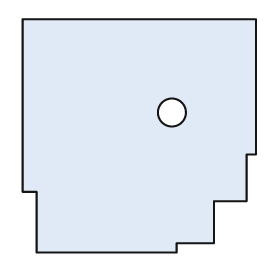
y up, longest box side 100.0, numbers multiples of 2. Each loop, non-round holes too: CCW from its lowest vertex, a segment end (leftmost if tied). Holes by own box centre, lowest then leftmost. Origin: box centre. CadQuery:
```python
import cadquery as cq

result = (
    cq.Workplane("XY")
    .moveTo(-44.0, -50.0)
    .lineTo(16.0, -50.0)
    .lineTo(16.0, -46.0)
    .lineTo(32.0, -46.0)
    .lineTo(32.0, -28.0)
    .lineTo(46.0, -28.0)
    .lineTo(46.0, -8.0)
    .lineTo(50.0, -8.0)
    .lineTo(50.0, 50.0)
    .lineTo(-50.0, 50.0)
    .lineTo(-50.0, -24.0)
    .lineTo(-44.0, -24.0)
    .close()
    .moveTo(14.0, 10.0)
    .circle(6.0)
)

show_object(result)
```